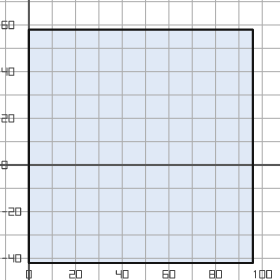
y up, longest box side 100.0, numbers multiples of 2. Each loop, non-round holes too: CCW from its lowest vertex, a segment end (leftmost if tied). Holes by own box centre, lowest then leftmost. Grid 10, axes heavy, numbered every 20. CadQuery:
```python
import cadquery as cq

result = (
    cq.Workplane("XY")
    .moveTo(0.0, -42.0)
    .lineTo(96.0, -42.0)
    .lineTo(96.0, 58.0)
    .lineTo(0.0, 58.0)
    .close()
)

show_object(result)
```